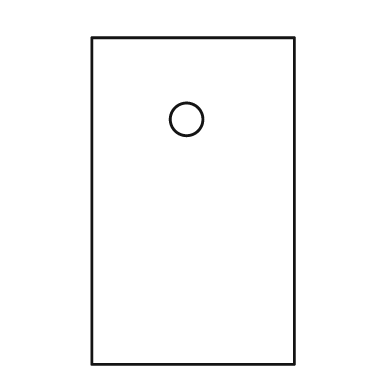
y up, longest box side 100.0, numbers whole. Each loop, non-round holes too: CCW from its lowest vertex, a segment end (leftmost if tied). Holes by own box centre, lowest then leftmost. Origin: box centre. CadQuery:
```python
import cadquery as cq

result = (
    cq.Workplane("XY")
    .moveTo(-31.0, -50.0)
    .lineTo(31.0, -50.0)
    .lineTo(31.0, 50.0)
    .lineTo(-31.0, 50.0)
    .close()
    .moveTo(-2.0, 25.0)
    .circle(5.0)
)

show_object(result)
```